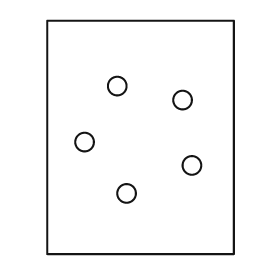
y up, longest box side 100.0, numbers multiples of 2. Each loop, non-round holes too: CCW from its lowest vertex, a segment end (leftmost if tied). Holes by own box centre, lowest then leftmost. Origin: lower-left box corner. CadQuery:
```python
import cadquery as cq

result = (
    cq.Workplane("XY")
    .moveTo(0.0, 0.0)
    .lineTo(80.0, 0.0)
    .lineTo(80.0, 100.0)
    .lineTo(0.0, 100.0)
    .close()
    .moveTo(34.0, 26.0)
    .circle(4.0)
    .moveTo(62.0, 38.0)
    .circle(4.0)
    .moveTo(16.0, 48.0)
    .circle(4.0)
    .moveTo(58.0, 66.0)
    .circle(4.0)
    .moveTo(30.0, 72.0)
    .circle(4.0)
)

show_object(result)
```